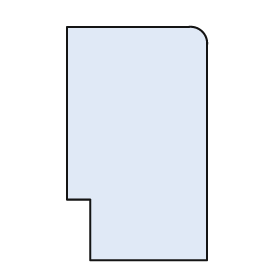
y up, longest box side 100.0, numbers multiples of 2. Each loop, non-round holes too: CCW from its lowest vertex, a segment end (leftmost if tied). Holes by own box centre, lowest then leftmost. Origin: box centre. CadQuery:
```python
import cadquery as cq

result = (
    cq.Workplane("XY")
    .moveTo(-20.0, -50.0)
    .lineTo(30.0, -50.0)
    .lineTo(30.0, 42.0)
    .threePointArc((28.0, 48.0), (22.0, 50.0))
    .lineTo(-30.0, 50.0)
    .lineTo(-30.0, -24.0)
    .lineTo(-20.0, -24.0)
    .close()
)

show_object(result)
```